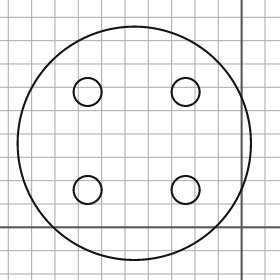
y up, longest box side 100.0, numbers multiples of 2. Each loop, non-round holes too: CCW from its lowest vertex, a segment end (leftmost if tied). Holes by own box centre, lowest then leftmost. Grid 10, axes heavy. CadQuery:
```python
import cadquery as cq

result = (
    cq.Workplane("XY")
    .moveTo(-46.0, 36.0)
    .circle(50.0)
    .moveTo(-66.0, 16.0)
    .circle(6.0)
    .moveTo(-24.0, 16.0)
    .circle(6.0)
    .moveTo(-66.0, 58.0)
    .circle(6.0)
    .moveTo(-24.0, 58.0)
    .circle(6.0)
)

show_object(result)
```